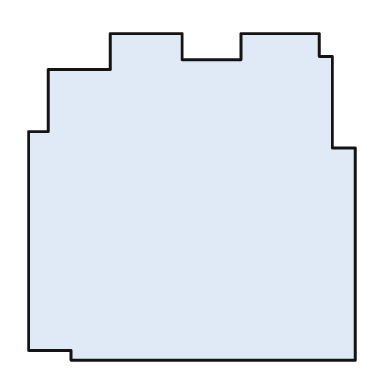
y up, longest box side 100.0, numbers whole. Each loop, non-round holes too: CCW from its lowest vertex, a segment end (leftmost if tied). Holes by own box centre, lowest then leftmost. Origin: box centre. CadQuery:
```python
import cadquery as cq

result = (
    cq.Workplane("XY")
    .moveTo(-37.0, -50.0)
    .lineTo(50.0, -50.0)
    .lineTo(50.0, 15.0)
    .lineTo(43.0, 15.0)
    .lineTo(43.0, 43.0)
    .lineTo(39.0, 43.0)
    .lineTo(39.0, 50.0)
    .lineTo(15.0, 50.0)
    .lineTo(15.0, 42.0)
    .lineTo(-3.0, 42.0)
    .lineTo(-3.0, 50.0)
    .lineTo(-25.0, 50.0)
    .lineTo(-25.0, 39.0)
    .lineTo(-44.0, 39.0)
    .lineTo(-44.0, 20.0)
    .lineTo(-50.0, 20.0)
    .lineTo(-50.0, -47.0)
    .lineTo(-37.0, -47.0)
    .close()
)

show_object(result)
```